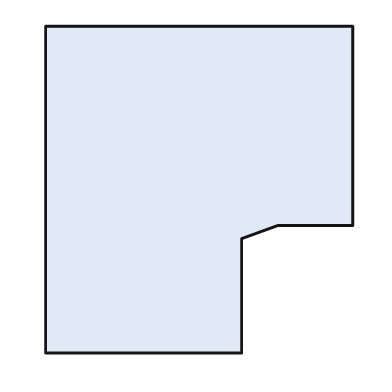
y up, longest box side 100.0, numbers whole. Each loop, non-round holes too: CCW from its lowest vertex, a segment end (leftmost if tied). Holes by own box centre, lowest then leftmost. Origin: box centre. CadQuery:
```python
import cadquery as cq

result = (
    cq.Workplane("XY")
    .moveTo(-47.0, -50.0)
    .lineTo(13.0, -50.0)
    .lineTo(13.0, -15.0)
    .lineTo(24.0, -11.0)
    .lineTo(47.0, -11.0)
    .lineTo(47.0, 50.0)
    .lineTo(-47.0, 50.0)
    .close()
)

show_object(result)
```